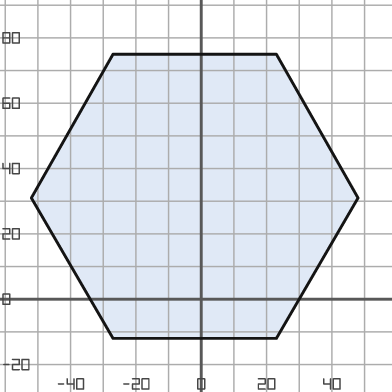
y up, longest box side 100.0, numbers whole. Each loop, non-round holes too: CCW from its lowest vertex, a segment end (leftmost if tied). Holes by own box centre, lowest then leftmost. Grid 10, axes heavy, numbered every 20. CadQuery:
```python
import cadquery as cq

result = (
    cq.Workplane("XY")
    .moveTo(-27.0, -12.0)
    .lineTo(23.0, -12.0)
    .lineTo(48.0, 31.0)
    .lineTo(23.0, 75.0)
    .lineTo(-27.0, 75.0)
    .lineTo(-52.0, 31.0)
    .close()
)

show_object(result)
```